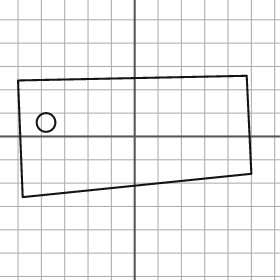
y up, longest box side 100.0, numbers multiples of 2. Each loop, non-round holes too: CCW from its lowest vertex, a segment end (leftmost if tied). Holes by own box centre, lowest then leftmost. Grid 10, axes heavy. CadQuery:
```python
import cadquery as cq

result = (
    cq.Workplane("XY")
    .moveTo(-48.0, -26.0)
    .lineTo(50.0, -16.0)
    .lineTo(48.0, 26.0)
    .lineTo(-50.0, 24.0)
    .close()
    .moveTo(-38.0, 6.0)
    .circle(4.0)
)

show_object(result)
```